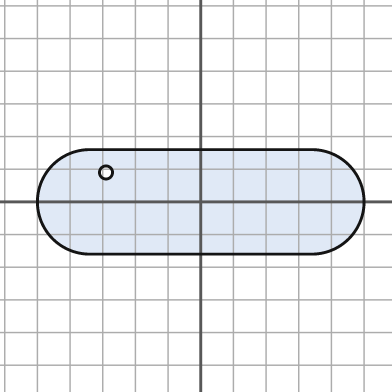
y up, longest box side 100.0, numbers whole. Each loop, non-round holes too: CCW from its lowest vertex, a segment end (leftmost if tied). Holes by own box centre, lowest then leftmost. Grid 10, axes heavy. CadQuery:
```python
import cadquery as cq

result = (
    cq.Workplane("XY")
    .moveTo(-34.0, -16.0)
    .lineTo(34.0, -16.0)
    .threePointArc((50.0, 0.0), (34.0, 16.0))
    .lineTo(-34.0, 16.0)
    .threePointArc((-50.0, 0.0), (-34.0, -16.0))
    .close()
    .moveTo(-29.0, 9.0)
    .circle(2.0)
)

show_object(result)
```